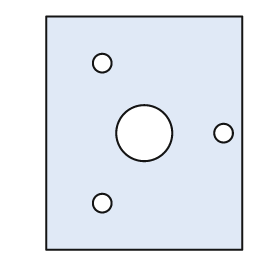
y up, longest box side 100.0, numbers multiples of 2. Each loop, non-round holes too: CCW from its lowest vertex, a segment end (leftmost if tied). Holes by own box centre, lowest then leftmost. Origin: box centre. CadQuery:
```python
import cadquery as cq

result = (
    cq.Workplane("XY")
    .moveTo(-42.0, -50.0)
    .lineTo(42.0, -50.0)
    .lineTo(42.0, 50.0)
    .lineTo(-42.0, 50.0)
    .close()
    .moveTo(-18.0, -30.0)
    .circle(4.0)
    .moveTo(0.0, 0.0)
    .circle(12.0)
    .moveTo(34.0, 0.0)
    .circle(4.0)
    .moveTo(-18.0, 30.0)
    .circle(4.0)
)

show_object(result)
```